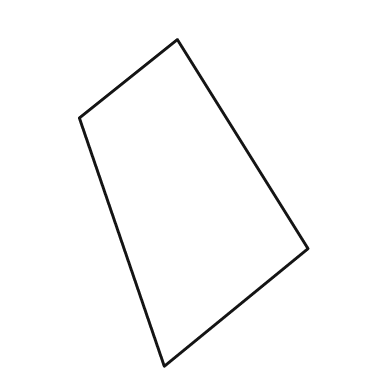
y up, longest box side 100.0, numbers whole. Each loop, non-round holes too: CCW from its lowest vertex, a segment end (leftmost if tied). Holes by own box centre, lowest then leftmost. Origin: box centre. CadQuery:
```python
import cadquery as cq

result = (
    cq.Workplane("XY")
    .moveTo(-9.0, -50.0)
    .lineTo(35.0, -14.0)
    .lineTo(-5.0, 50.0)
    .lineTo(-35.0, 26.0)
    .close()
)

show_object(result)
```